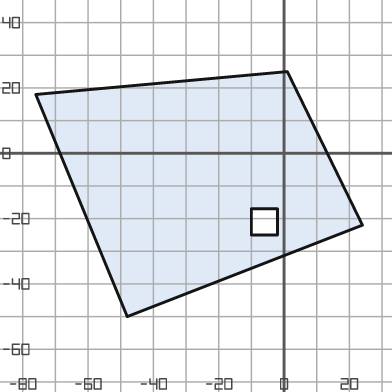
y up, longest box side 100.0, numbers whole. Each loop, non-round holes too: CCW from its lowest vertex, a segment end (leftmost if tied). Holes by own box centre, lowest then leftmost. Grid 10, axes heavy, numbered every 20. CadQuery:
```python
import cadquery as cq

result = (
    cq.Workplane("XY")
    .moveTo(-48.0, -50.0)
    .lineTo(24.0, -22.0)
    .lineTo(1.0, 25.0)
    .lineTo(-76.0, 18.0)
    .close()
    .moveTo(-10.0, -25.0)
    .lineTo(-2.0, -25.0)
    .lineTo(-2.0, -17.0)
    .lineTo(-10.0, -17.0)
    .close()
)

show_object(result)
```